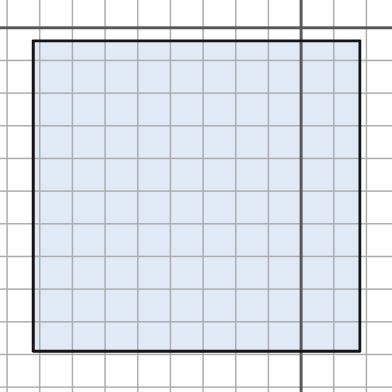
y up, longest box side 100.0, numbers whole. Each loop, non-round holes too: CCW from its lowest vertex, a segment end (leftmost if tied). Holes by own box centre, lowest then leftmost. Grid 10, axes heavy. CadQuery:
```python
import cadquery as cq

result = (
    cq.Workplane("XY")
    .moveTo(-82.0, -99.0)
    .lineTo(18.0, -99.0)
    .lineTo(18.0, -4.0)
    .lineTo(-82.0, -4.0)
    .close()
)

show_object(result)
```